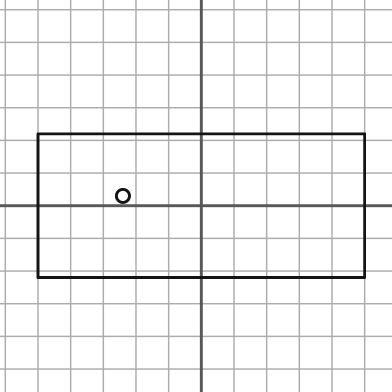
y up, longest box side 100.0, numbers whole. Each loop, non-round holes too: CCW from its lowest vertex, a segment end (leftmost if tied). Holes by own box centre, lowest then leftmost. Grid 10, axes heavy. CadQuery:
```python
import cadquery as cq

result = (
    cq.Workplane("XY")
    .moveTo(-50.0, -22.0)
    .lineTo(50.0, -22.0)
    .lineTo(50.0, 22.0)
    .lineTo(-50.0, 22.0)
    .close()
    .moveTo(-24.0, 3.0)
    .circle(2.0)
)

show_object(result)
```